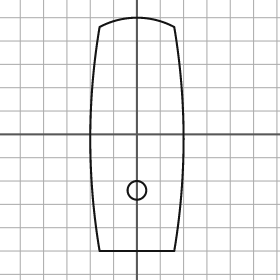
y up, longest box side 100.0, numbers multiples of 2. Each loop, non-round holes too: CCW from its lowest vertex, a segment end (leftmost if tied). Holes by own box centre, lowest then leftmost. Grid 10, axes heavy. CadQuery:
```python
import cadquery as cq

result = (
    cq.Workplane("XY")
    .moveTo(-16.0, -50.0)
    .lineTo(16.0, -50.0)
    .threePointArc((20.0, -2.0), (16.0, 46.0))
    .threePointArc((0.0, 50.0), (-16.0, 46.0))
    .threePointArc((-20.0, -2.0), (-16.0, -50.0))
    .close()
    .moveTo(0.0, -24.0)
    .circle(4.0)
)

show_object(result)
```